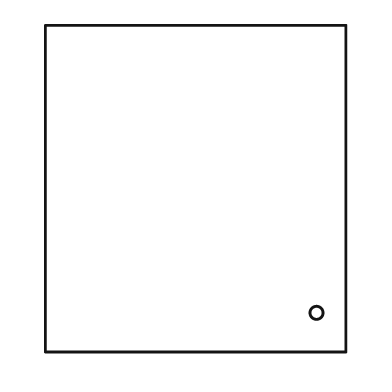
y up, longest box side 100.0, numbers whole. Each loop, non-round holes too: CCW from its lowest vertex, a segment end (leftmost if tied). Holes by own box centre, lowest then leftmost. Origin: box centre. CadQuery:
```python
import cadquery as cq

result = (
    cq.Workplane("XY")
    .moveTo(-46.0, -50.0)
    .lineTo(46.0, -50.0)
    .lineTo(46.0, 50.0)
    .lineTo(-46.0, 50.0)
    .close()
    .moveTo(37.0, -38.0)
    .circle(2.0)
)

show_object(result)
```